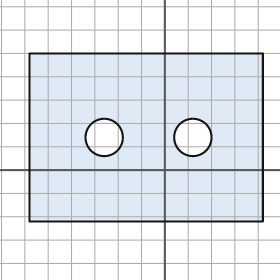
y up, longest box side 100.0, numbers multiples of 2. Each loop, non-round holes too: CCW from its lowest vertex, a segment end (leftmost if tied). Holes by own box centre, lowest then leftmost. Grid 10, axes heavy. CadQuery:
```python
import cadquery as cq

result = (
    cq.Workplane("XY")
    .moveTo(-58.0, -22.0)
    .lineTo(42.0, -22.0)
    .lineTo(42.0, 50.0)
    .lineTo(-58.0, 50.0)
    .close()
    .moveTo(-26.0, 14.0)
    .circle(8.0)
    .moveTo(12.0, 14.0)
    .circle(8.0)
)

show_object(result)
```